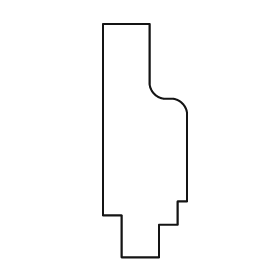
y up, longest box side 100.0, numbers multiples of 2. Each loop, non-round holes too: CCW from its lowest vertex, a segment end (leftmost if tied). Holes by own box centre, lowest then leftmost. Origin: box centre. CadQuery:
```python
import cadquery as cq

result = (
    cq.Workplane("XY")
    .moveTo(-10.0, -50.0)
    .lineTo(6.0, -50.0)
    .lineTo(6.0, -36.0)
    .lineTo(14.0, -36.0)
    .lineTo(14.0, -26.0)
    .lineTo(18.0, -26.0)
    .lineTo(18.0, 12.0)
    .threePointArc((16.0, 16.0), (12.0, 18.0))
    .lineTo(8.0, 18.0)
    .threePointArc((4.0, 20.0), (2.0, 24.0))
    .lineTo(2.0, 50.0)
    .lineTo(-18.0, 50.0)
    .lineTo(-18.0, -32.0)
    .lineTo(-10.0, -32.0)
    .close()
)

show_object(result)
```